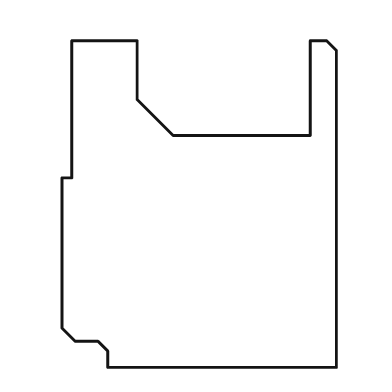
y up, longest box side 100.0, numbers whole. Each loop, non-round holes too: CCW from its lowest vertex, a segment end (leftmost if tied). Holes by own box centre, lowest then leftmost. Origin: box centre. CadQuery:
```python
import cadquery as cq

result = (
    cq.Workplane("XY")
    .moveTo(-28.0, -50.0)
    .lineTo(42.0, -50.0)
    .lineTo(42.0, 47.0)
    .lineTo(39.0, 50.0)
    .lineTo(34.0, 50.0)
    .lineTo(34.0, 21.0)
    .lineTo(-8.0, 21.0)
    .lineTo(-19.0, 32.0)
    .lineTo(-19.0, 50.0)
    .lineTo(-39.0, 50.0)
    .lineTo(-39.0, 8.0)
    .lineTo(-42.0, 8.0)
    .lineTo(-42.0, -38.0)
    .lineTo(-38.0, -42.0)
    .lineTo(-31.0, -42.0)
    .lineTo(-28.0, -45.0)
    .close()
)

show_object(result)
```